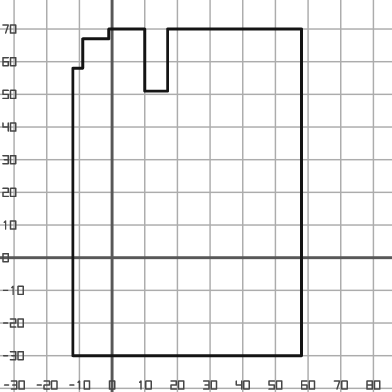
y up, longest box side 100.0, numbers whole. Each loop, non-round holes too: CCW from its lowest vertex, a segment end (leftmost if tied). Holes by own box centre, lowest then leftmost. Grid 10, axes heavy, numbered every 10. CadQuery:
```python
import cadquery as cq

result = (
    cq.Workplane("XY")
    .moveTo(-12.0, -30.0)
    .lineTo(58.0, -30.0)
    .lineTo(58.0, 70.0)
    .lineTo(17.0, 70.0)
    .lineTo(17.0, 51.0)
    .lineTo(10.0, 51.0)
    .lineTo(10.0, 70.0)
    .lineTo(-1.0, 70.0)
    .lineTo(-1.0, 67.0)
    .lineTo(-9.0, 67.0)
    .lineTo(-9.0, 58.0)
    .lineTo(-12.0, 58.0)
    .close()
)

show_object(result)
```